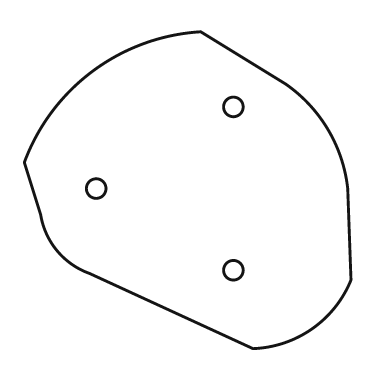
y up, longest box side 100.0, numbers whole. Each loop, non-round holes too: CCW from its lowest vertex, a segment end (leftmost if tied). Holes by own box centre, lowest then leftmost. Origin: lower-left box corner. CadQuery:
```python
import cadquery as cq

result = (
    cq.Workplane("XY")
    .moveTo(70.0, 0.0)
    .threePointArc((88.0, 6.0), (100.0, 21.0))
    .lineTo(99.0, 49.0)
    .threePointArc((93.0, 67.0), (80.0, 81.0))
    .lineTo(54.0, 97.0)
    .threePointArc((21.0, 85.0), (0.0, 57.0))
    .lineTo(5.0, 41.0)
    .threePointArc((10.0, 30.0), (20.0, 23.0))
    .close()
    .moveTo(64.0, 24.0)
    .circle(3.0)
    .moveTo(22.0, 49.0)
    .circle(3.0)
    .moveTo(64.0, 74.0)
    .circle(3.0)
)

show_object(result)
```